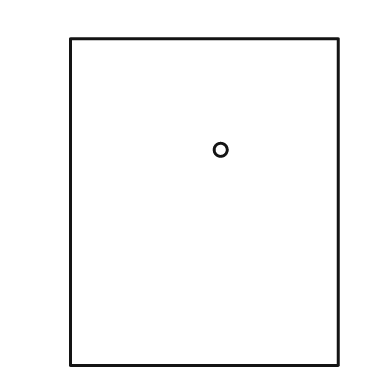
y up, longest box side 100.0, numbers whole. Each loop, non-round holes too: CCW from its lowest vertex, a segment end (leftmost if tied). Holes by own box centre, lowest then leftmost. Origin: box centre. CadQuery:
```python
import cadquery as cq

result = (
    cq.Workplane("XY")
    .moveTo(-41.0, -50.0)
    .lineTo(41.0, -50.0)
    .lineTo(41.0, 50.0)
    .lineTo(-41.0, 50.0)
    .close()
    .moveTo(5.0, 16.0)
    .circle(2.0)
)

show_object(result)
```